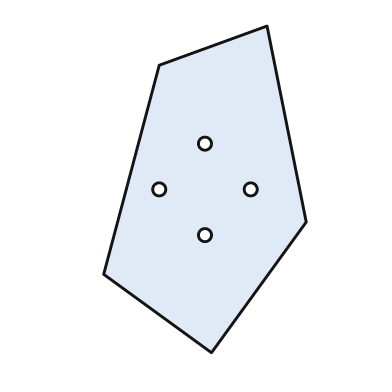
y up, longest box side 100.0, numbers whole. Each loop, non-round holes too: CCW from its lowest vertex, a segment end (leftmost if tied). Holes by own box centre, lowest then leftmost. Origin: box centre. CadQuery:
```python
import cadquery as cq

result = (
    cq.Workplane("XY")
    .moveTo(2.0, -50.0)
    .lineTo(31.0, -10.0)
    .lineTo(19.0, 50.0)
    .lineTo(-14.0, 38.0)
    .lineTo(-31.0, -26.0)
    .close()
    .moveTo(0.0, -14.0)
    .circle(2.0)
    .moveTo(-14.0, 0.0)
    .circle(2.0)
    .moveTo(14.0, 0.0)
    .circle(2.0)
    .moveTo(0.0, 14.0)
    .circle(2.0)
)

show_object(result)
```